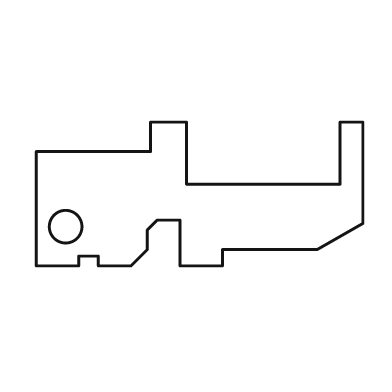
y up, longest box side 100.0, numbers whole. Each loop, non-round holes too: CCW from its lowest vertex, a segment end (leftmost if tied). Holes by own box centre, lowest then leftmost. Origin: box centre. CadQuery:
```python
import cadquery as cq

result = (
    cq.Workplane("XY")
    .moveTo(-50.0, -22.0)
    .lineTo(-37.0, -22.0)
    .lineTo(-37.0, -19.0)
    .lineTo(-31.0, -19.0)
    .lineTo(-31.0, -22.0)
    .lineTo(-21.0, -22.0)
    .lineTo(-16.0, -17.0)
    .lineTo(-16.0, -11.0)
    .lineTo(-13.0, -8.0)
    .lineTo(-6.0, -8.0)
    .lineTo(-6.0, -22.0)
    .lineTo(7.0, -22.0)
    .lineTo(7.0, -17.0)
    .lineTo(36.0, -17.0)
    .lineTo(50.0, -9.0)
    .lineTo(50.0, 22.0)
    .lineTo(43.0, 22.0)
    .lineTo(43.0, 3.0)
    .lineTo(-4.0, 3.0)
    .lineTo(-4.0, 22.0)
    .lineTo(-15.0, 22.0)
    .lineTo(-15.0, 13.0)
    .lineTo(-50.0, 13.0)
    .close()
    .moveTo(-41.0, -10.0)
    .circle(5.0)
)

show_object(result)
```